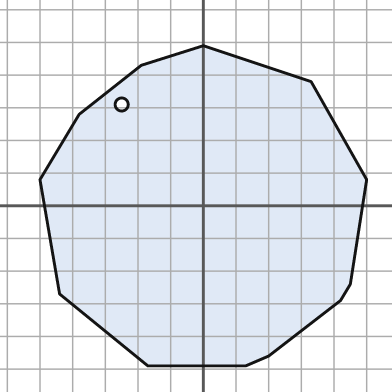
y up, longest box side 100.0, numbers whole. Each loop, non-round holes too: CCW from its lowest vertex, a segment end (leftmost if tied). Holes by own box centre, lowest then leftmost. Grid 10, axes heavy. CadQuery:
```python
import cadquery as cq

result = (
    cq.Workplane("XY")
    .moveTo(-17.0, -49.0)
    .lineTo(13.0, -49.0)
    .lineTo(20.0, -46.0)
    .lineTo(42.0, -29.0)
    .lineTo(45.0, -24.0)
    .lineTo(50.0, 8.0)
    .lineTo(33.0, 38.0)
    .lineTo(0.0, 49.0)
    .lineTo(-19.0, 43.0)
    .lineTo(-38.0, 28.0)
    .lineTo(-50.0, 8.0)
    .lineTo(-44.0, -27.0)
    .close()
    .moveTo(-25.0, 31.0)
    .circle(2.0)
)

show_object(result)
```